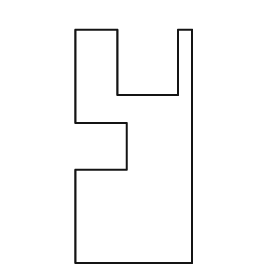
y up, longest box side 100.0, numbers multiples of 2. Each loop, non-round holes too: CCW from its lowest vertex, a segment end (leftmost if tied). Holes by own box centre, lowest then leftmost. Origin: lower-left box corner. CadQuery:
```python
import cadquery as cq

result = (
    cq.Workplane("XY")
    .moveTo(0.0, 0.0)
    .lineTo(50.0, 0.0)
    .lineTo(50.0, 100.0)
    .lineTo(44.0, 100.0)
    .lineTo(44.0, 72.0)
    .lineTo(18.0, 72.0)
    .lineTo(18.0, 100.0)
    .lineTo(0.0, 100.0)
    .lineTo(0.0, 60.0)
    .lineTo(22.0, 60.0)
    .lineTo(22.0, 40.0)
    .lineTo(0.0, 40.0)
    .close()
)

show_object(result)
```